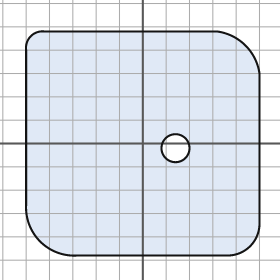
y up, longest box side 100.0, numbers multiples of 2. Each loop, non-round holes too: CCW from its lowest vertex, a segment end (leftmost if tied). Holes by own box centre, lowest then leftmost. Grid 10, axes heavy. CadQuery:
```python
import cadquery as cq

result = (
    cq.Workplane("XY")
    .moveTo(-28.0, -48.0)
    .lineTo(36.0, -48.0)
    .threePointArc((46.0, -44.0), (50.0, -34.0))
    .lineTo(50.0, 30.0)
    .threePointArc((44.0, 42.0), (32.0, 48.0))
    .lineTo(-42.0, 48.0)
    .threePointArc((-48.0, 46.0), (-50.0, 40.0))
    .lineTo(-50.0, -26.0)
    .threePointArc((-44.0, -42.0), (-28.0, -48.0))
    .close()
    .moveTo(14.0, -2.0)
    .circle(6.0)
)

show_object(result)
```